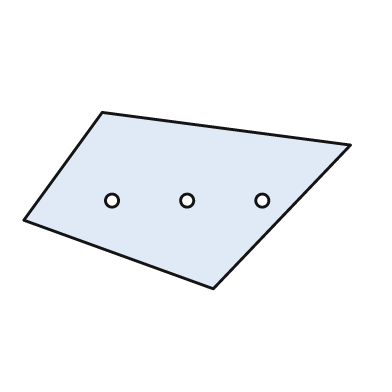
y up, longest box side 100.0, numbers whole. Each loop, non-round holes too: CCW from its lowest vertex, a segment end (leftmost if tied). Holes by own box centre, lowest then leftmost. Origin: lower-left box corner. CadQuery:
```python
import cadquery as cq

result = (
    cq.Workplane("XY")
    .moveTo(58.0, 0.0)
    .lineTo(100.0, 44.0)
    .lineTo(24.0, 54.0)
    .lineTo(0.0, 21.0)
    .close()
    .moveTo(27.0, 27.0)
    .circle(2.0)
    .moveTo(50.0, 27.0)
    .circle(2.0)
    .moveTo(73.0, 27.0)
    .circle(2.0)
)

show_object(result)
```